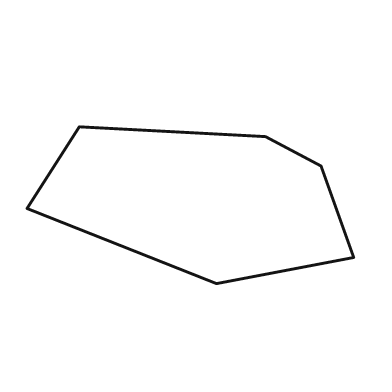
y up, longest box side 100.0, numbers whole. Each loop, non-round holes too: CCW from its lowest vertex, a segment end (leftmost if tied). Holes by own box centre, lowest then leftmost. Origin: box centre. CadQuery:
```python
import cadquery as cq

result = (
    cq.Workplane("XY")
    .moveTo(8.0, -24.0)
    .lineTo(50.0, -16.0)
    .lineTo(40.0, 12.0)
    .lineTo(23.0, 21.0)
    .lineTo(-34.0, 24.0)
    .lineTo(-50.0, -1.0)
    .close()
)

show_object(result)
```